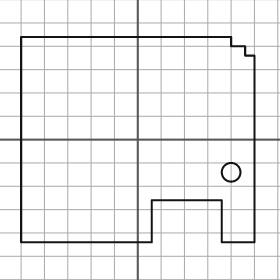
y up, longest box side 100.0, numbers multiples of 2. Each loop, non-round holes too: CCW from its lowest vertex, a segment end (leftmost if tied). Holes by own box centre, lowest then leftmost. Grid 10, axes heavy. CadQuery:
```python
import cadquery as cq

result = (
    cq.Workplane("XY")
    .moveTo(-50.0, -44.0)
    .lineTo(6.0, -44.0)
    .lineTo(6.0, -26.0)
    .lineTo(36.0, -26.0)
    .lineTo(36.0, -44.0)
    .lineTo(50.0, -44.0)
    .lineTo(50.0, 36.0)
    .lineTo(46.0, 36.0)
    .lineTo(46.0, 40.0)
    .lineTo(40.0, 40.0)
    .lineTo(40.0, 44.0)
    .lineTo(-50.0, 44.0)
    .close()
    .moveTo(40.0, -14.0)
    .circle(4.0)
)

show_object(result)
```